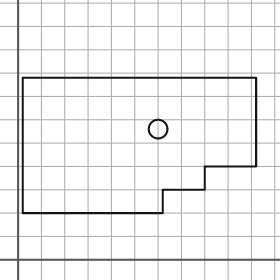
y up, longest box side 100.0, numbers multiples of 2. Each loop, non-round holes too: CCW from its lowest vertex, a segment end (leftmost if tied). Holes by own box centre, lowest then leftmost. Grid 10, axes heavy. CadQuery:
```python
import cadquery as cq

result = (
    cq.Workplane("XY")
    .moveTo(2.0, 20.0)
    .lineTo(62.0, 20.0)
    .lineTo(62.0, 30.0)
    .lineTo(80.0, 30.0)
    .lineTo(80.0, 40.0)
    .lineTo(102.0, 40.0)
    .lineTo(102.0, 78.0)
    .lineTo(2.0, 78.0)
    .close()
    .moveTo(60.0, 56.0)
    .circle(4.0)
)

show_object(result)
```